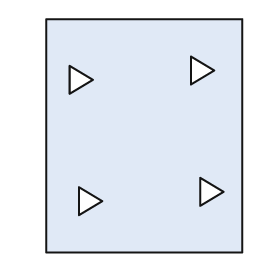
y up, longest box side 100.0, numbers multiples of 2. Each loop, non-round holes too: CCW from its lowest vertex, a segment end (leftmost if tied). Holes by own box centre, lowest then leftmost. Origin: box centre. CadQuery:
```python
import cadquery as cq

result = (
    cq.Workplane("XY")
    .moveTo(-42.0, -50.0)
    .lineTo(42.0, -50.0)
    .lineTo(42.0, 50.0)
    .lineTo(-42.0, 50.0)
    .close()
    .moveTo(-28.0, -34.0)
    .lineTo(-18.0, -28.0)
    .lineTo(-28.0, -22.0)
    .close()
    .moveTo(24.0, -30.0)
    .lineTo(34.0, -24.0)
    .lineTo(24.0, -18.0)
    .close()
    .moveTo(-32.0, 18.0)
    .lineTo(-22.0, 24.0)
    .lineTo(-32.0, 30.0)
    .close()
    .moveTo(20.0, 22.0)
    .lineTo(30.0, 28.0)
    .lineTo(20.0, 34.0)
    .close()
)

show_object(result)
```